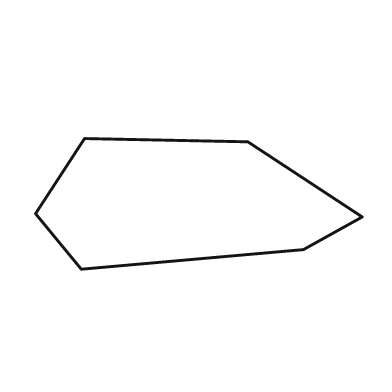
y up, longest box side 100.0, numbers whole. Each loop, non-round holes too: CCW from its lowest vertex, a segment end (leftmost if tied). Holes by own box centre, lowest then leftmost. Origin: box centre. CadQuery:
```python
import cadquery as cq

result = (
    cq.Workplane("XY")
    .moveTo(-36.0, -20.0)
    .lineTo(32.0, -14.0)
    .lineTo(50.0, -4.0)
    .lineTo(15.0, 19.0)
    .lineTo(-35.0, 20.0)
    .lineTo(-50.0, -3.0)
    .close()
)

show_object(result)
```